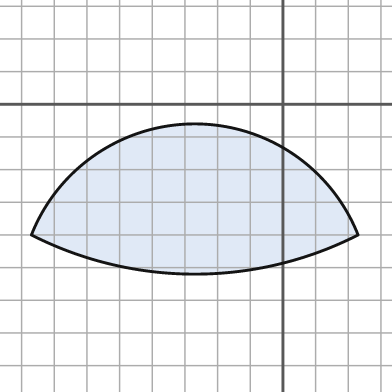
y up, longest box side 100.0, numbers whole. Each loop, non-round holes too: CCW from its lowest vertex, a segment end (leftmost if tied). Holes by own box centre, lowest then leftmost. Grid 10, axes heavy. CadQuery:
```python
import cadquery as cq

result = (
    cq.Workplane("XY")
    .moveTo(-77.0, -40.0)
    .threePointArc((-27.0, -52.0), (23.0, -40.0))
    .threePointArc((-27.0, -6.0), (-77.0, -40.0))
    .close()
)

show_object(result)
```